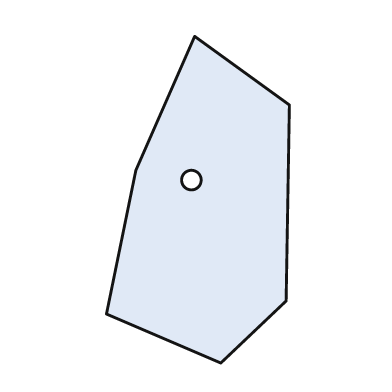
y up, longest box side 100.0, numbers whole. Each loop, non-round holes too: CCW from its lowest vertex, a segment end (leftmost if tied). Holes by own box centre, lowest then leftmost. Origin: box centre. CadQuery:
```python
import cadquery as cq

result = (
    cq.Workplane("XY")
    .moveTo(7.0, -50.0)
    .lineTo(27.0, -31.0)
    .lineTo(28.0, 29.0)
    .lineTo(-1.0, 50.0)
    .lineTo(-19.0, 9.0)
    .lineTo(-28.0, -35.0)
    .close()
    .moveTo(-2.0, 6.0)
    .circle(3.0)
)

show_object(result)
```